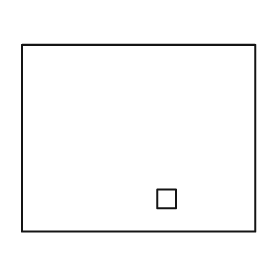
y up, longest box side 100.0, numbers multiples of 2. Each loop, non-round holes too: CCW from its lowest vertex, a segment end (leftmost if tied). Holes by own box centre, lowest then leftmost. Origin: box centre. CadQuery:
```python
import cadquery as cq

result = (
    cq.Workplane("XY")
    .moveTo(-50.0, -40.0)
    .lineTo(50.0, -40.0)
    .lineTo(50.0, 40.0)
    .lineTo(-50.0, 40.0)
    .close()
    .moveTo(8.0, -30.0)
    .lineTo(16.0, -30.0)
    .lineTo(16.0, -22.0)
    .lineTo(8.0, -22.0)
    .close()
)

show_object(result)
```